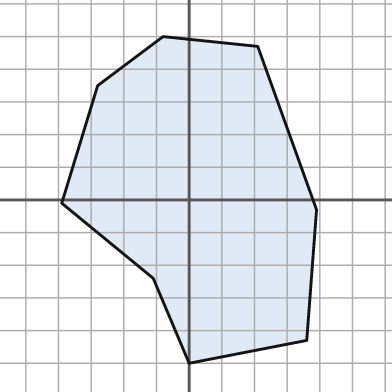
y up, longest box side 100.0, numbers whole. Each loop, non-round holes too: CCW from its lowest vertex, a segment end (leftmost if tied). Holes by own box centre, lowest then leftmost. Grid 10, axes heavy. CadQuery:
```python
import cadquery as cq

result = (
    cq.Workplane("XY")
    .moveTo(0.0, -50.0)
    .lineTo(36.0, -43.0)
    .lineTo(39.0, -3.0)
    .lineTo(21.0, 47.0)
    .lineTo(-8.0, 50.0)
    .lineTo(-28.0, 35.0)
    .lineTo(-39.0, -1.0)
    .lineTo(-11.0, -24.0)
    .close()
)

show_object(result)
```